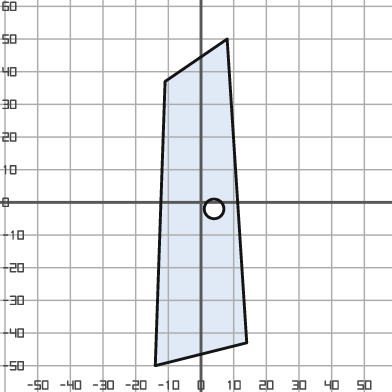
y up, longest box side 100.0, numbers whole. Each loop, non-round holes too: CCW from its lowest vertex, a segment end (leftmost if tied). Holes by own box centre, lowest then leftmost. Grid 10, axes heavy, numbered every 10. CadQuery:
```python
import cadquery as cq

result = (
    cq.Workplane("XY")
    .moveTo(-14.0, -50.0)
    .lineTo(14.0, -43.0)
    .lineTo(8.0, 50.0)
    .lineTo(-11.0, 37.0)
    .close()
    .moveTo(4.0, -2.0)
    .circle(3.0)
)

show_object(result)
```